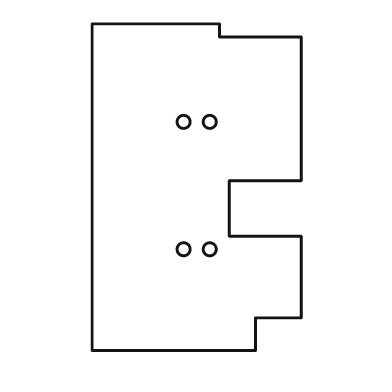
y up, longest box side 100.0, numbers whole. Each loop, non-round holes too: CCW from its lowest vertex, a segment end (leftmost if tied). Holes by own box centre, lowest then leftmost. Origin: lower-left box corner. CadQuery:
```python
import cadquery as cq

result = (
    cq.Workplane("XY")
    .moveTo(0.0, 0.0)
    .lineTo(50.0, 0.0)
    .lineTo(50.0, 10.0)
    .lineTo(64.0, 10.0)
    .lineTo(64.0, 35.0)
    .lineTo(42.0, 35.0)
    .lineTo(42.0, 52.0)
    .lineTo(64.0, 52.0)
    .lineTo(64.0, 96.0)
    .lineTo(39.0, 96.0)
    .lineTo(39.0, 100.0)
    .lineTo(0.0, 100.0)
    .close()
    .moveTo(28.0, 31.0)
    .circle(2.0)
    .moveTo(36.0, 31.0)
    .circle(2.0)
    .moveTo(28.0, 70.0)
    .circle(2.0)
    .moveTo(36.0, 70.0)
    .circle(2.0)
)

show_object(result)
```